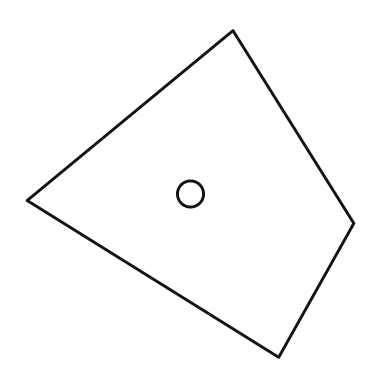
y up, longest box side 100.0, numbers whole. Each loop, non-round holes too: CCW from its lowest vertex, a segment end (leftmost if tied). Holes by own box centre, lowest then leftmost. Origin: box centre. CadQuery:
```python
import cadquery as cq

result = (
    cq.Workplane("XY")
    .moveTo(27.0, -50.0)
    .lineTo(50.0, -9.0)
    .lineTo(13.0, 50.0)
    .lineTo(-50.0, -2.0)
    .close()
    .moveTo(0.0, 0.0)
    .circle(4.0)
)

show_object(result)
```